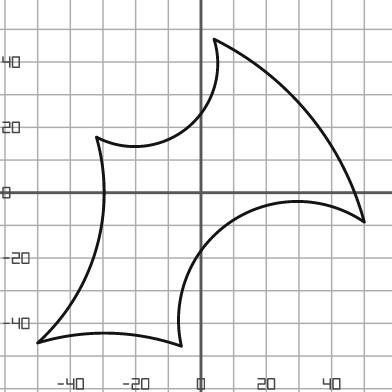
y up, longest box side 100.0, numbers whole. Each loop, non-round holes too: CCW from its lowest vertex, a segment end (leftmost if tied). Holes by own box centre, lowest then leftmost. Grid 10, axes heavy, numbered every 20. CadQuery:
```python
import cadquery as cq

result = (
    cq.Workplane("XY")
    .moveTo(-6.0, -47.0)
    .threePointArc((9.0, -9.0), (50.0, -9.0))
    .threePointArc((33.0, 24.0), (4.0, 47.0))
    .threePointArc((-4.0, 20.0), (-32.0, 17.0))
    .threePointArc((-32.0, -17.0), (-50.0, -46.0))
    .threePointArc((-28.0, -43.0), (-6.0, -47.0))
    .close()
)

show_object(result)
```